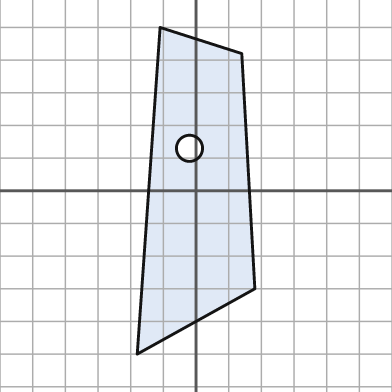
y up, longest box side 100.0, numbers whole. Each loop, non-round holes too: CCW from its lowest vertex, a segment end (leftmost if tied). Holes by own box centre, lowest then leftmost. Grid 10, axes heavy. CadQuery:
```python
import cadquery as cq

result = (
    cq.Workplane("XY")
    .moveTo(-18.0, -50.0)
    .lineTo(18.0, -30.0)
    .lineTo(14.0, 42.0)
    .lineTo(-11.0, 50.0)
    .close()
    .moveTo(-2.0, 13.0)
    .circle(4.0)
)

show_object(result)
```